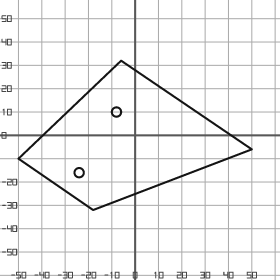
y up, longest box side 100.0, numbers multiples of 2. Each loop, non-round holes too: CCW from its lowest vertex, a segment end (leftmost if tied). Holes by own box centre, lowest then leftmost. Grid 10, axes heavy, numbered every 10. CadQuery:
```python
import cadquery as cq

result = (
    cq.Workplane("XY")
    .moveTo(-18.0, -32.0)
    .lineTo(50.0, -6.0)
    .lineTo(-6.0, 32.0)
    .lineTo(-50.0, -10.0)
    .close()
    .moveTo(-24.0, -16.0)
    .circle(2.0)
    .moveTo(-8.0, 10.0)
    .circle(2.0)
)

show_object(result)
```